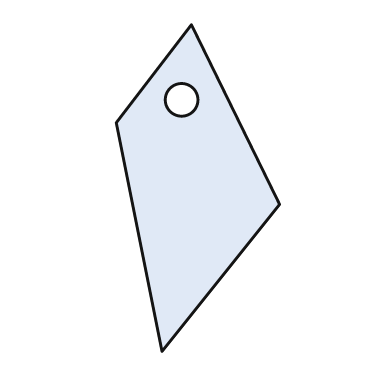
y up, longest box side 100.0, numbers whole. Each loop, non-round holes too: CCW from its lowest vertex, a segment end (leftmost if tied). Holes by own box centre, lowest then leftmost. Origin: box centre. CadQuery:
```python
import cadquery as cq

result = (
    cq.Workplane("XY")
    .moveTo(-11.0, -50.0)
    .lineTo(25.0, -5.0)
    .lineTo(-2.0, 50.0)
    .lineTo(-25.0, 20.0)
    .close()
    .moveTo(-5.0, 27.0)
    .circle(5.0)
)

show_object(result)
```